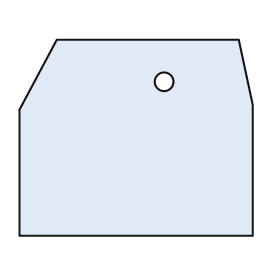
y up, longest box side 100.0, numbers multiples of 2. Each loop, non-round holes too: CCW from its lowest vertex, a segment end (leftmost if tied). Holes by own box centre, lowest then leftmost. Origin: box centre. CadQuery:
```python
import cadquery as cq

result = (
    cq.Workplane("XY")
    .moveTo(-50.0, -42.0)
    .lineTo(50.0, -42.0)
    .lineTo(50.0, 14.0)
    .lineTo(44.0, 42.0)
    .lineTo(-34.0, 42.0)
    .lineTo(-50.0, 12.0)
    .close()
    .moveTo(12.0, 24.0)
    .circle(4.0)
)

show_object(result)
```